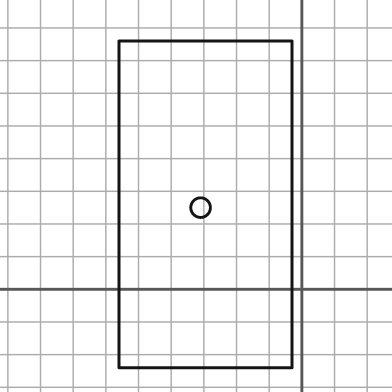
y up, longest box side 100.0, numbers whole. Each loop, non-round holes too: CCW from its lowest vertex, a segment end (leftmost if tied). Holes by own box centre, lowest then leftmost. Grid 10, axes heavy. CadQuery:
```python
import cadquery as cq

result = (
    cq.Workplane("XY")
    .moveTo(-56.0, -24.0)
    .lineTo(-3.0, -24.0)
    .lineTo(-3.0, 76.0)
    .lineTo(-56.0, 76.0)
    .close()
    .moveTo(-31.0, 25.0)
    .circle(3.0)
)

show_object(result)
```